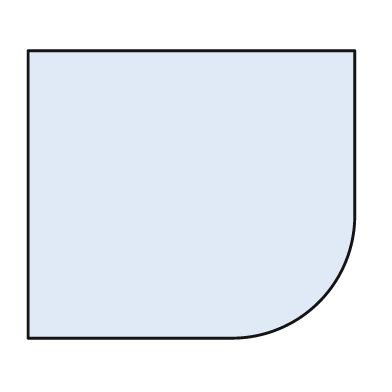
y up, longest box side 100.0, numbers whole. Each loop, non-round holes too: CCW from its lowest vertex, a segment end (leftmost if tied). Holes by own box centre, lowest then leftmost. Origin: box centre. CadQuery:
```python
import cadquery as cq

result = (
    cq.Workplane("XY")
    .moveTo(-50.0, -44.0)
    .lineTo(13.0, -44.0)
    .threePointArc((39.0, -33.0), (50.0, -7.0))
    .lineTo(50.0, 44.0)
    .lineTo(-50.0, 44.0)
    .close()
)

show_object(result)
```